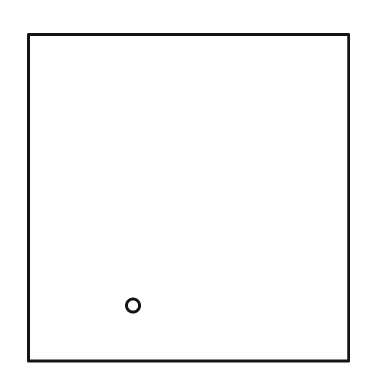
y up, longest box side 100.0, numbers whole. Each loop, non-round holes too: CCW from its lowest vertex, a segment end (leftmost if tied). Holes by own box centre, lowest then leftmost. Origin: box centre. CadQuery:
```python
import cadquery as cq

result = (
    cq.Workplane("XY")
    .moveTo(-49.0, -50.0)
    .lineTo(49.0, -50.0)
    .lineTo(49.0, 50.0)
    .lineTo(-49.0, 50.0)
    .close()
    .moveTo(-17.0, -33.0)
    .circle(2.0)
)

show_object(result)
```